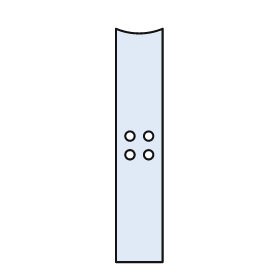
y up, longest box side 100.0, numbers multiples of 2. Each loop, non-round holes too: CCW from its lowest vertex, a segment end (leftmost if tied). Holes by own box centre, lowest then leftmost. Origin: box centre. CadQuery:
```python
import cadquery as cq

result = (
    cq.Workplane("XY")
    .moveTo(-10.0, -50.0)
    .lineTo(10.0, -50.0)
    .lineTo(10.0, 50.0)
    .threePointArc((0.0, 48.0), (-10.0, 50.0))
    .close()
    .moveTo(-4.0, -4.0)
    .circle(2.0)
    .moveTo(4.0, -4.0)
    .circle(2.0)
    .moveTo(-4.0, 4.0)
    .circle(2.0)
    .moveTo(4.0, 4.0)
    .circle(2.0)
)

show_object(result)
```